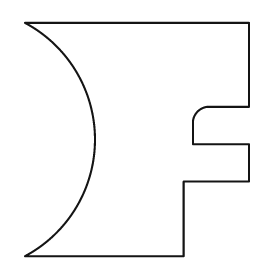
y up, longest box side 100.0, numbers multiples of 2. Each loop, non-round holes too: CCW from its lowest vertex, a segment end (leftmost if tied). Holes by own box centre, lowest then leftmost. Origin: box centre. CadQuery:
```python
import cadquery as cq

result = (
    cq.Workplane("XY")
    .moveTo(-48.0, -50.0)
    .lineTo(20.0, -50.0)
    .lineTo(20.0, -18.0)
    .lineTo(48.0, -18.0)
    .lineTo(48.0, -2.0)
    .lineTo(24.0, -2.0)
    .lineTo(24.0, 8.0)
    .threePointArc((26.0, 12.0), (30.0, 14.0))
    .lineTo(48.0, 14.0)
    .lineTo(48.0, 50.0)
    .lineTo(-48.0, 50.0)
    .threePointArc((-18.0, 0.0), (-48.0, -50.0))
    .close()
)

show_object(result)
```